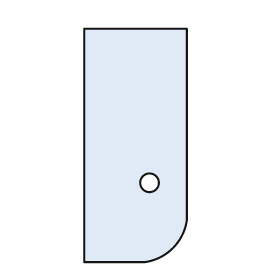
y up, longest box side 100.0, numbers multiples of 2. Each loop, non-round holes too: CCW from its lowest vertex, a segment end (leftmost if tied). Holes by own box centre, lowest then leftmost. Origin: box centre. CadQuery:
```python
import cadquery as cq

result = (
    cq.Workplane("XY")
    .moveTo(-22.0, -50.0)
    .lineTo(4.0, -50.0)
    .threePointArc((16.0, -44.0), (22.0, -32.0))
    .lineTo(22.0, 50.0)
    .lineTo(-22.0, 50.0)
    .close()
    .moveTo(6.0, -16.0)
    .circle(4.0)
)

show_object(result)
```